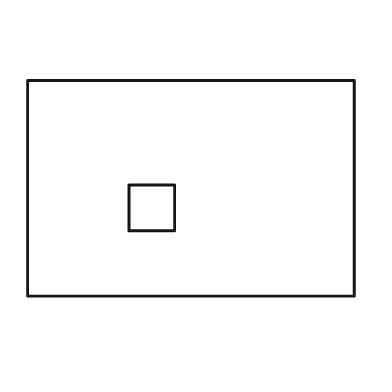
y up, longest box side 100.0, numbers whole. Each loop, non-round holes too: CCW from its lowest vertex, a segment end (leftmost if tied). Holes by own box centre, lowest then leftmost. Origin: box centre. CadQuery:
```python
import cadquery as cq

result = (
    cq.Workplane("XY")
    .moveTo(-50.0, -33.0)
    .lineTo(50.0, -33.0)
    .lineTo(50.0, 33.0)
    .lineTo(-50.0, 33.0)
    .close()
    .moveTo(-19.0, -13.0)
    .lineTo(-5.0, -13.0)
    .lineTo(-5.0, 1.0)
    .lineTo(-19.0, 1.0)
    .close()
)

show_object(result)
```